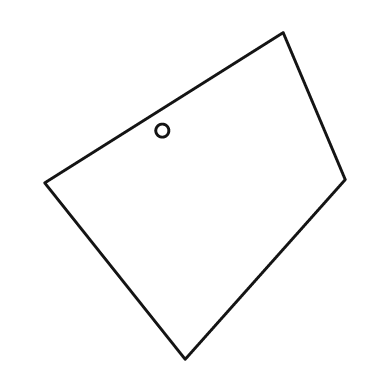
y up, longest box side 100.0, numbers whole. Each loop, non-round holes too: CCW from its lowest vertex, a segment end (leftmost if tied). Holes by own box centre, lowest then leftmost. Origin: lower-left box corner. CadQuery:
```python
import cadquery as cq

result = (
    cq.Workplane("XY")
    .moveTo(43.0, 0.0)
    .lineTo(92.0, 55.0)
    .lineTo(73.0, 100.0)
    .lineTo(0.0, 54.0)
    .close()
    .moveTo(36.0, 70.0)
    .circle(2.0)
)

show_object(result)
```